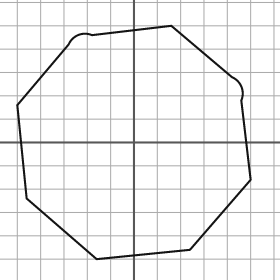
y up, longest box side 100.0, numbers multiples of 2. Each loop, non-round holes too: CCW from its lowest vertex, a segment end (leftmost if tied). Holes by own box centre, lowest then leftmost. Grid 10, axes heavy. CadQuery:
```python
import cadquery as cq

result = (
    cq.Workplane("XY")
    .moveTo(-16.0, -50.0)
    .lineTo(24.0, -46.0)
    .lineTo(50.0, -16.0)
    .lineTo(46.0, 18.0)
    .threePointArc((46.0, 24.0), (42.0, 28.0))
    .lineTo(16.0, 50.0)
    .lineTo(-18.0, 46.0)
    .threePointArc((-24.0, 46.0), (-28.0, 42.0))
    .lineTo(-50.0, 16.0)
    .lineTo(-46.0, -24.0)
    .close()
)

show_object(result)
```